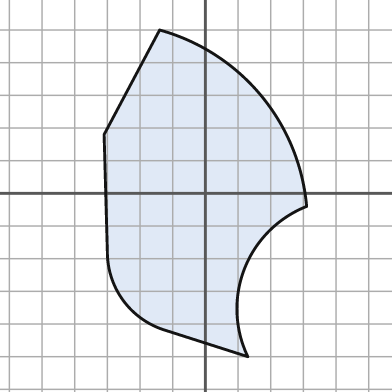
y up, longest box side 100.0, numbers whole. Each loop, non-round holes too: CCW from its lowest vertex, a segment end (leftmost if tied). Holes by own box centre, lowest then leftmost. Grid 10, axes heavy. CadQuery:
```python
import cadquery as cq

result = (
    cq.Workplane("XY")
    .moveTo(13.0, -50.0)
    .threePointArc((12.0, -23.0), (31.0, -4.0))
    .threePointArc((17.0, 30.0), (-14.0, 50.0))
    .lineTo(-31.0, 18.0)
    .lineTo(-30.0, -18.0)
    .threePointArc((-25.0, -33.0), (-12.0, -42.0))
    .close()
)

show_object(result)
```